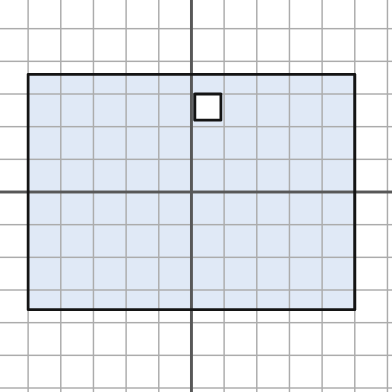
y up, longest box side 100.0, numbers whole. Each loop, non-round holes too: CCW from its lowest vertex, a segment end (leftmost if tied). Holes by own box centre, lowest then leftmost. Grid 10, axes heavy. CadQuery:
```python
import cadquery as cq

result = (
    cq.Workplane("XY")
    .moveTo(-50.0, -36.0)
    .lineTo(50.0, -36.0)
    .lineTo(50.0, 36.0)
    .lineTo(-50.0, 36.0)
    .close()
    .moveTo(1.0, 22.0)
    .lineTo(9.0, 22.0)
    .lineTo(9.0, 30.0)
    .lineTo(1.0, 30.0)
    .close()
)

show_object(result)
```